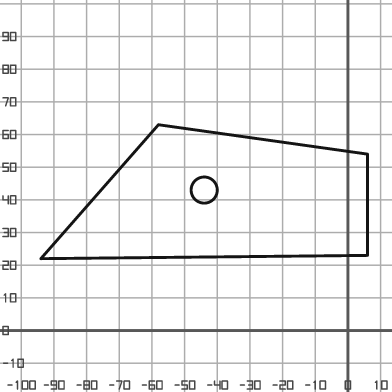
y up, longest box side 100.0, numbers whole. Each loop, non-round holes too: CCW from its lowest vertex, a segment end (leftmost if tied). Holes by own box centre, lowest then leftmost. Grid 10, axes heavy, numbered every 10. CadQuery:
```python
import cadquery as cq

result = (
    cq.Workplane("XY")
    .moveTo(-94.0, 22.0)
    .lineTo(6.0, 23.0)
    .lineTo(6.0, 54.0)
    .lineTo(-58.0, 63.0)
    .close()
    .moveTo(-44.0, 43.0)
    .circle(4.0)
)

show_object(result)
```